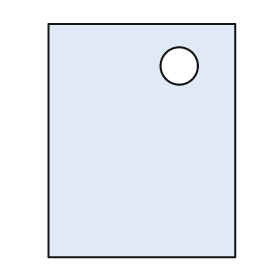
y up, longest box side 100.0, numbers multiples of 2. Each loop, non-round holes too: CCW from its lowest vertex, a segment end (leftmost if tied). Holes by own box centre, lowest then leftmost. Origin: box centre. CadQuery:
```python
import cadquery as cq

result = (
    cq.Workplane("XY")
    .moveTo(-40.0, -50.0)
    .lineTo(40.0, -50.0)
    .lineTo(40.0, 50.0)
    .lineTo(-40.0, 50.0)
    .close()
    .moveTo(16.0, 32.0)
    .circle(8.0)
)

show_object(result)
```